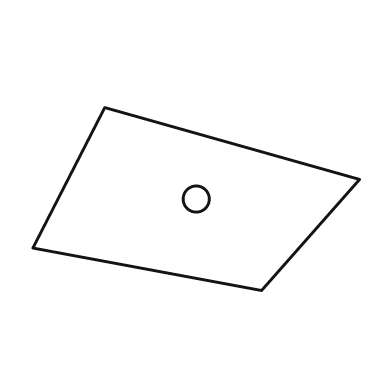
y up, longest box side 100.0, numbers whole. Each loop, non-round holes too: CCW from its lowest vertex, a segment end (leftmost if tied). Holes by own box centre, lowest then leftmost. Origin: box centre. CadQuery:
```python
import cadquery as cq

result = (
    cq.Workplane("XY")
    .moveTo(20.0, -28.0)
    .lineTo(50.0, 6.0)
    .lineTo(-28.0, 28.0)
    .lineTo(-50.0, -15.0)
    .close()
    .moveTo(0.0, 0.0)
    .circle(4.0)
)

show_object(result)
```